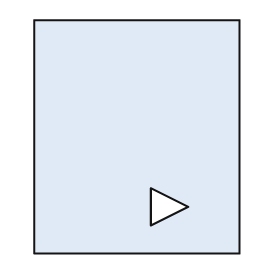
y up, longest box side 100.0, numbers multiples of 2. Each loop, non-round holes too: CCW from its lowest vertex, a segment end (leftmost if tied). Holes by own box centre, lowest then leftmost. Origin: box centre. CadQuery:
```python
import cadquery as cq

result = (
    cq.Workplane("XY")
    .moveTo(-44.0, -50.0)
    .lineTo(44.0, -50.0)
    .lineTo(44.0, 50.0)
    .lineTo(-44.0, 50.0)
    .close()
    .moveTo(6.0, -38.0)
    .lineTo(22.0, -30.0)
    .lineTo(6.0, -22.0)
    .close()
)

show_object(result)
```